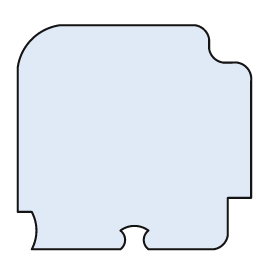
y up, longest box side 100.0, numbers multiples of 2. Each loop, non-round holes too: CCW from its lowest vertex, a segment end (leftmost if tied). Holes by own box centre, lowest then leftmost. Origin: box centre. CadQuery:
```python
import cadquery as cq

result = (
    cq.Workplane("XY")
    .moveTo(-44.0, -48.0)
    .lineTo(-6.0, -48.0)
    .threePointArc((-4.0, -44.0), (-6.0, -40.0))
    .threePointArc((0.0, -38.0), (6.0, -40.0))
    .threePointArc((4.0, -44.0), (6.0, -48.0))
    .lineTo(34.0, -48.0)
    .threePointArc((38.0, -46.0), (40.0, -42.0))
    .lineTo(40.0, -26.0)
    .lineTo(50.0, -26.0)
    .lineTo(50.0, 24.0)
    .threePointArc((48.0, 30.0), (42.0, 32.0))
    .lineTo(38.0, 32.0)
    .threePointArc((34.0, 34.0), (32.0, 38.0))
    .lineTo(32.0, 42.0)
    .threePointArc((30.0, 46.0), (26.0, 48.0))
    .lineTo(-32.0, 48.0)
    .threePointArc((-44.0, 42.0), (-50.0, 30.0))
    .lineTo(-50.0, -32.0)
    .lineTo(-44.0, -32.0)
    .threePointArc((-42.0, -40.0), (-44.0, -48.0))
    .close()
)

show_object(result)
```